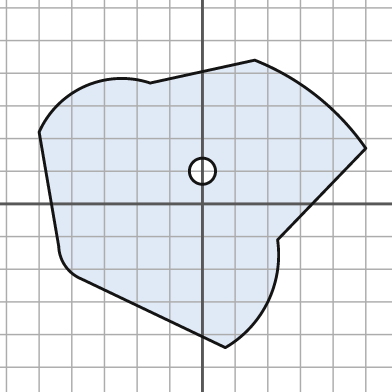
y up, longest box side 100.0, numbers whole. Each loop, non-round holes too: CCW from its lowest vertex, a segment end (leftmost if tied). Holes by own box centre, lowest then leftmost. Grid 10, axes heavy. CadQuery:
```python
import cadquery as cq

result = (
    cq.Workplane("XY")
    .moveTo(7.0, -44.0)
    .threePointArc((20.0, -30.0), (23.0, -11.0))
    .lineTo(50.0, 17.0)
    .threePointArc((35.0, 33.0), (16.0, 44.0))
    .lineTo(-16.0, 37.0)
    .threePointArc((-36.0, 36.0), (-50.0, 22.0))
    .lineTo(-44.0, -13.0)
    .threePointArc((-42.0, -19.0), (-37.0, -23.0))
    .close()
    .moveTo(0.0, 10.0)
    .circle(4.0)
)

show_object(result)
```